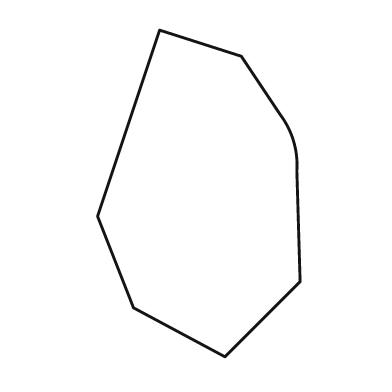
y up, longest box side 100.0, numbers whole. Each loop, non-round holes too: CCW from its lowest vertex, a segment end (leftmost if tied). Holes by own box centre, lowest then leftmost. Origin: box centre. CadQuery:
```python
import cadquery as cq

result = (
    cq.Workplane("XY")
    .moveTo(8.0, -50.0)
    .lineTo(31.0, -27.0)
    .lineTo(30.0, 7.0)
    .threePointArc((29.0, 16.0), (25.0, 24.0))
    .lineTo(13.0, 42.0)
    .lineTo(-12.0, 50.0)
    .lineTo(-31.0, -7.0)
    .lineTo(-20.0, -35.0)
    .close()
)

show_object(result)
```